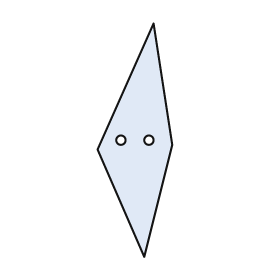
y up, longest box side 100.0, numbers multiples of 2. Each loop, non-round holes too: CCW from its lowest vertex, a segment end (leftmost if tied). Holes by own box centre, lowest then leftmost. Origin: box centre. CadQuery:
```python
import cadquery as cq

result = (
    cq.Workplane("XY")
    .moveTo(4.0, -50.0)
    .lineTo(16.0, -2.0)
    .lineTo(8.0, 50.0)
    .lineTo(-16.0, -4.0)
    .close()
    .moveTo(-6.0, 0.0)
    .circle(2.0)
    .moveTo(6.0, 0.0)
    .circle(2.0)
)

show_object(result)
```